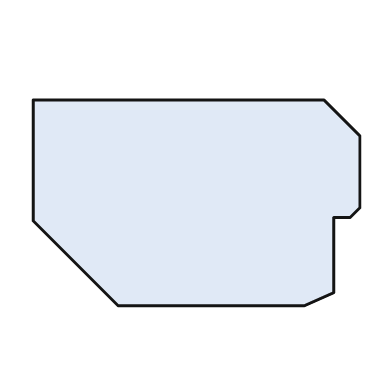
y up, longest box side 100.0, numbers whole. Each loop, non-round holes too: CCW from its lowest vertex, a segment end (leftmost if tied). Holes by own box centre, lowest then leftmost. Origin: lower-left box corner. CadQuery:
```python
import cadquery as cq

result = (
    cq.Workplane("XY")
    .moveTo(26.0, 0.0)
    .lineTo(83.0, 0.0)
    .lineTo(92.0, 4.0)
    .lineTo(92.0, 27.0)
    .lineTo(97.0, 27.0)
    .lineTo(100.0, 30.0)
    .lineTo(100.0, 52.0)
    .lineTo(89.0, 63.0)
    .lineTo(0.0, 63.0)
    .lineTo(0.0, 26.0)
    .close()
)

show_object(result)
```